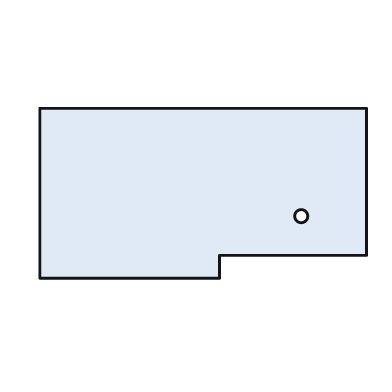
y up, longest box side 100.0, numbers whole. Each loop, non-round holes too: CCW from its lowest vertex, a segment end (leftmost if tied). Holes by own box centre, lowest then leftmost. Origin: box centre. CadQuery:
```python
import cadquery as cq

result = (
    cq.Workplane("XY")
    .moveTo(-50.0, -26.0)
    .lineTo(5.0, -26.0)
    .lineTo(5.0, -19.0)
    .lineTo(50.0, -19.0)
    .lineTo(50.0, 26.0)
    .lineTo(-50.0, 26.0)
    .close()
    .moveTo(30.0, -7.0)
    .circle(2.0)
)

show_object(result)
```